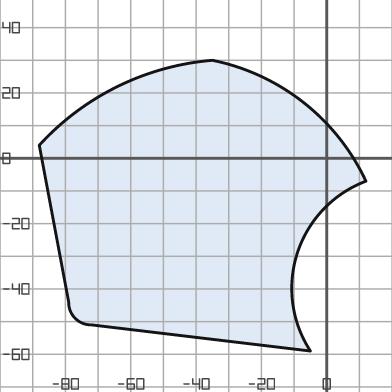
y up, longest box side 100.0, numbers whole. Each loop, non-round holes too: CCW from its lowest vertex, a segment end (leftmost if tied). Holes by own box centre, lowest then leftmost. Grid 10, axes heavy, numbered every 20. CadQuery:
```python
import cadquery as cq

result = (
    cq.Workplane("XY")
    .moveTo(-5.0, -59.0)
    .threePointArc((-9.0, -29.0), (12.0, -7.0))
    .threePointArc((-7.0, 17.0), (-35.0, 30.0))
    .threePointArc((-64.0, 22.0), (-88.0, 4.0))
    .lineTo(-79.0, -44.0)
    .threePointArc((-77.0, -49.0), (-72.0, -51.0))
    .close()
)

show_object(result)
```